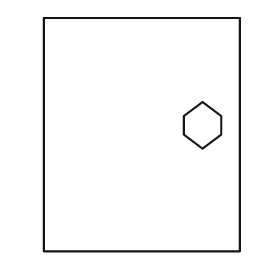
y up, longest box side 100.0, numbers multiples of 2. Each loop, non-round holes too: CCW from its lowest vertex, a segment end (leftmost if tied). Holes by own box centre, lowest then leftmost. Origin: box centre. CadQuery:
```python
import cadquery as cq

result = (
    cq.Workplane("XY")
    .moveTo(-42.0, -50.0)
    .lineTo(42.0, -50.0)
    .lineTo(42.0, 50.0)
    .lineTo(-42.0, 50.0)
    .close()
    .moveTo(26.0, -6.0)
    .lineTo(34.0, 0.0)
    .lineTo(34.0, 8.0)
    .lineTo(26.0, 14.0)
    .lineTo(18.0, 8.0)
    .lineTo(18.0, 0.0)
    .close()
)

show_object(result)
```